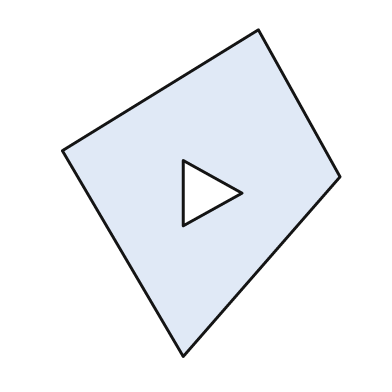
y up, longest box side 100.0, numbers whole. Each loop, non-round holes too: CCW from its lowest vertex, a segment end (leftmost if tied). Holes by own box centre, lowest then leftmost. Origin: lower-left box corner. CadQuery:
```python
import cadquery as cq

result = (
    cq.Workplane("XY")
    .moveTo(37.0, 0.0)
    .lineTo(85.0, 55.0)
    .lineTo(60.0, 100.0)
    .lineTo(0.0, 63.0)
    .close()
    .moveTo(37.0, 40.0)
    .lineTo(55.0, 50.0)
    .lineTo(37.0, 60.0)
    .close()
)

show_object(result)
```